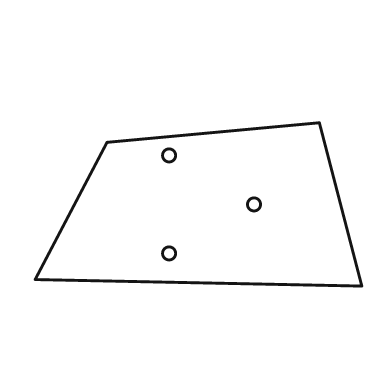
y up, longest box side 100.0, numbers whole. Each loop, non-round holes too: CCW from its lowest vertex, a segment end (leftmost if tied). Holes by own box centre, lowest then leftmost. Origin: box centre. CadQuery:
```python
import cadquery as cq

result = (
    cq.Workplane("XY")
    .moveTo(50.0, -25.0)
    .lineTo(37.0, 25.0)
    .lineTo(-28.0, 19.0)
    .lineTo(-50.0, -23.0)
    .close()
    .moveTo(-9.0, -15.0)
    .circle(2.0)
    .moveTo(17.0, 0.0)
    .circle(2.0)
    .moveTo(-9.0, 15.0)
    .circle(2.0)
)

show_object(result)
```